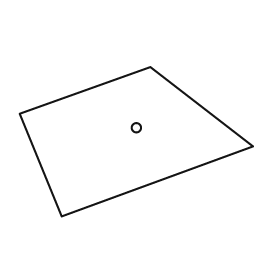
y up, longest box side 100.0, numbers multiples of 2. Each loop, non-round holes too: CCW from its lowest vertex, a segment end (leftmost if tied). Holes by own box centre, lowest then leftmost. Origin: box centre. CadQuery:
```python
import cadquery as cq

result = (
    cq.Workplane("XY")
    .moveTo(-32.0, -32.0)
    .lineTo(50.0, -2.0)
    .lineTo(6.0, 32.0)
    .lineTo(-50.0, 12.0)
    .close()
    .moveTo(0.0, 6.0)
    .circle(2.0)
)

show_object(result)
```